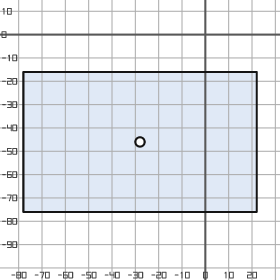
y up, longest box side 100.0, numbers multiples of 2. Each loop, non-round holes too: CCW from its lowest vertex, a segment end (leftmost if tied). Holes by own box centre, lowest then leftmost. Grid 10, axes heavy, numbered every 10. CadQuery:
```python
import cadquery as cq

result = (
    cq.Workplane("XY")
    .moveTo(-78.0, -76.0)
    .lineTo(22.0, -76.0)
    .lineTo(22.0, -16.0)
    .lineTo(-78.0, -16.0)
    .close()
    .moveTo(-28.0, -46.0)
    .circle(2.0)
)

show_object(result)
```